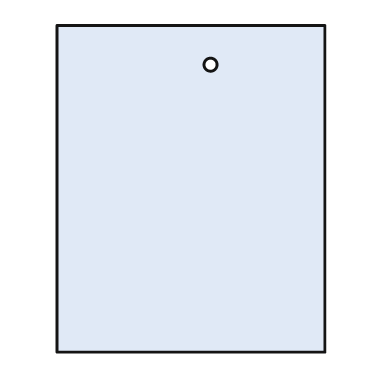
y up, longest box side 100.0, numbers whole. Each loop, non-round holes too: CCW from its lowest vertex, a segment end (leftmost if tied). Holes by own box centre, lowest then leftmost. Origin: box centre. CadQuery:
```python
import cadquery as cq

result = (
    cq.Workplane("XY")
    .moveTo(-41.0, -50.0)
    .lineTo(41.0, -50.0)
    .lineTo(41.0, 50.0)
    .lineTo(-41.0, 50.0)
    .close()
    .moveTo(6.0, 38.0)
    .circle(2.0)
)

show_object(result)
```